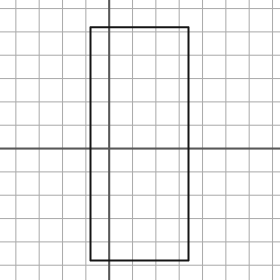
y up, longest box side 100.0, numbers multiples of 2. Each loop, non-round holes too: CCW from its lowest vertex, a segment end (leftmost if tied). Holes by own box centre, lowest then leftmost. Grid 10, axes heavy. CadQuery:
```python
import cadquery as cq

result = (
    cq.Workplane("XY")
    .moveTo(-8.0, -48.0)
    .lineTo(34.0, -48.0)
    .lineTo(34.0, 52.0)
    .lineTo(-8.0, 52.0)
    .close()
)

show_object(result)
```